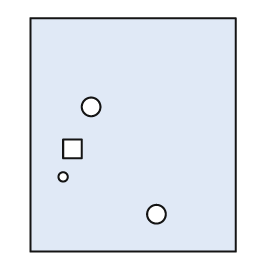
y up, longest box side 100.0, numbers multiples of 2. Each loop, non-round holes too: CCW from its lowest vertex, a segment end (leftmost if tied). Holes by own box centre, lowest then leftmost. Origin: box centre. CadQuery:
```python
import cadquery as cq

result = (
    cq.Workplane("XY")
    .moveTo(-44.0, -50.0)
    .lineTo(44.0, -50.0)
    .lineTo(44.0, 50.0)
    .lineTo(-44.0, 50.0)
    .close()
    .moveTo(10.0, -34.0)
    .circle(4.0)
    .moveTo(-30.0, -18.0)
    .circle(2.0)
    .moveTo(-30.0, -10.0)
    .lineTo(-22.0, -10.0)
    .lineTo(-22.0, -2.0)
    .lineTo(-30.0, -2.0)
    .close()
    .moveTo(-18.0, 12.0)
    .circle(4.0)
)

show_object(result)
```